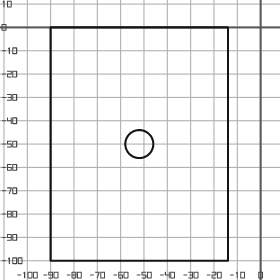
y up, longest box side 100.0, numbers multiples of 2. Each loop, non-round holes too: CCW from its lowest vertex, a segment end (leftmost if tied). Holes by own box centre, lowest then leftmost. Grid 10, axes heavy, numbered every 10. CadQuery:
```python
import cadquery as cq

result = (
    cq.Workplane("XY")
    .moveTo(-90.0, -100.0)
    .lineTo(-14.0, -100.0)
    .lineTo(-14.0, 0.0)
    .lineTo(-90.0, 0.0)
    .close()
    .moveTo(-52.0, -50.0)
    .circle(6.0)
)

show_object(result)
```